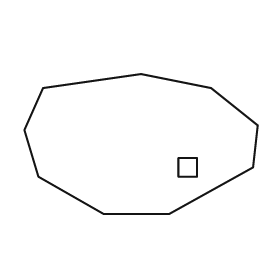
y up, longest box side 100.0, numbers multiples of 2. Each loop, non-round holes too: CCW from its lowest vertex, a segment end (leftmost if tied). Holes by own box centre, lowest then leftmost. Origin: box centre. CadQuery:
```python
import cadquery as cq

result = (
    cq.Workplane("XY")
    .moveTo(-16.0, -30.0)
    .lineTo(12.0, -30.0)
    .lineTo(48.0, -10.0)
    .lineTo(50.0, 8.0)
    .lineTo(30.0, 24.0)
    .lineTo(0.0, 30.0)
    .lineTo(-42.0, 24.0)
    .lineTo(-50.0, 6.0)
    .lineTo(-44.0, -14.0)
    .close()
    .moveTo(16.0, -14.0)
    .lineTo(24.0, -14.0)
    .lineTo(24.0, -6.0)
    .lineTo(16.0, -6.0)
    .close()
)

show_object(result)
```